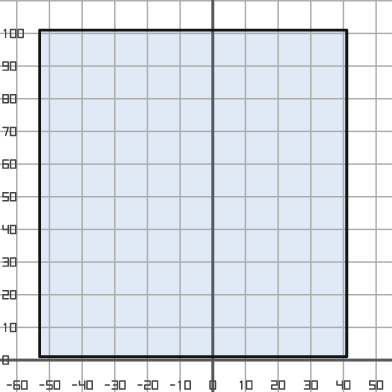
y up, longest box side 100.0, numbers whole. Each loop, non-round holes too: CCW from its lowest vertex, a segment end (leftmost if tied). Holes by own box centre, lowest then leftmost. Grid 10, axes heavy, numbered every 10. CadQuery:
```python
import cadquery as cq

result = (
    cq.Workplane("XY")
    .moveTo(-53.0, 1.0)
    .lineTo(41.0, 1.0)
    .lineTo(41.0, 101.0)
    .lineTo(-53.0, 101.0)
    .close()
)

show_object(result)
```